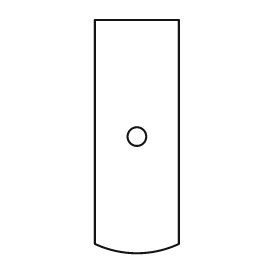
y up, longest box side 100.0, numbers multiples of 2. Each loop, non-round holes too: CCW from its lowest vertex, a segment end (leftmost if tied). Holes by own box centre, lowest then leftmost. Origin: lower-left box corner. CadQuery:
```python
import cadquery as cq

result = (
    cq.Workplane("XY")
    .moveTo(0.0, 4.0)
    .threePointArc((18.0, 0.0), (36.0, 4.0))
    .lineTo(36.0, 100.0)
    .lineTo(0.0, 100.0)
    .close()
    .moveTo(18.0, 50.0)
    .circle(4.0)
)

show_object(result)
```